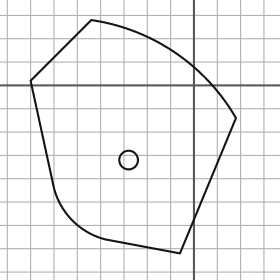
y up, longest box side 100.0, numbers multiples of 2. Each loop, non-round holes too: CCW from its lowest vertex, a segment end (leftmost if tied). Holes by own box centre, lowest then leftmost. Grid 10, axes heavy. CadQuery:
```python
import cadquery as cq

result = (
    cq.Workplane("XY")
    .moveTo(-6.0, -72.0)
    .lineTo(18.0, -14.0)
    .threePointArc((-8.0, 14.0), (-44.0, 28.0))
    .lineTo(-70.0, 2.0)
    .lineTo(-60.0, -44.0)
    .threePointArc((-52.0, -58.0), (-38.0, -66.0))
    .close()
    .moveTo(-28.0, -32.0)
    .circle(4.0)
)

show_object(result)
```